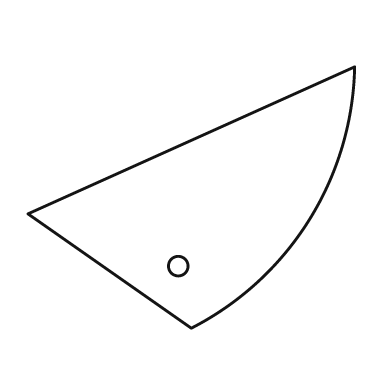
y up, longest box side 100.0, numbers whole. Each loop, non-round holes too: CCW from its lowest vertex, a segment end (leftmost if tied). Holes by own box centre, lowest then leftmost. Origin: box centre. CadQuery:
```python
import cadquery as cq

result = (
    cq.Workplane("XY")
    .moveTo(0.0, -40.0)
    .threePointArc((36.0, -7.0), (50.0, 40.0))
    .lineTo(-50.0, -5.0)
    .close()
    .moveTo(-4.0, -21.0)
    .circle(3.0)
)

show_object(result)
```